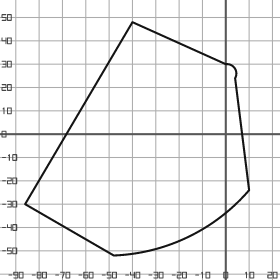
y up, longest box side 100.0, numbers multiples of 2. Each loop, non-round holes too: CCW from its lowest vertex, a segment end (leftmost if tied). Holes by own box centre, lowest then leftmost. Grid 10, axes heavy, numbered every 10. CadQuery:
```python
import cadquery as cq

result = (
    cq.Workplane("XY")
    .moveTo(-48.0, -52.0)
    .threePointArc((-16.0, -44.0), (10.0, -24.0))
    .lineTo(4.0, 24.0)
    .threePointArc((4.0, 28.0), (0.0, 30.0))
    .lineTo(-40.0, 48.0)
    .lineTo(-86.0, -30.0)
    .close()
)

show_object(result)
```